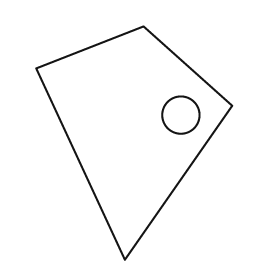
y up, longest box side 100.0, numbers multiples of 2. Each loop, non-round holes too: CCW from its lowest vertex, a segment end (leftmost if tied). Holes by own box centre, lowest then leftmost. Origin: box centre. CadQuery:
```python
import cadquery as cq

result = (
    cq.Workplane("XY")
    .moveTo(-4.0, -50.0)
    .lineTo(42.0, 16.0)
    .lineTo(4.0, 50.0)
    .lineTo(-42.0, 32.0)
    .close()
    .moveTo(20.0, 12.0)
    .circle(8.0)
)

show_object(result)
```